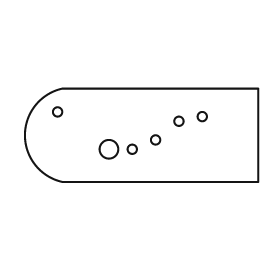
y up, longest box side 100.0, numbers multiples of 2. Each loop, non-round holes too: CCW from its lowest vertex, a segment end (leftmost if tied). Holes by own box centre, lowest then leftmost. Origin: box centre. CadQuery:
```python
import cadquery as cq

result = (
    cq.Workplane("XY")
    .moveTo(-34.0, -20.0)
    .lineTo(50.0, -20.0)
    .lineTo(50.0, 20.0)
    .lineTo(-34.0, 20.0)
    .threePointArc((-50.0, 0.0), (-34.0, -20.0))
    .close()
    .moveTo(-14.0, -6.0)
    .circle(4.0)
    .moveTo(-4.0, -6.0)
    .circle(2.0)
    .moveTo(6.0, -2.0)
    .circle(2.0)
    .moveTo(16.0, 6.0)
    .circle(2.0)
    .moveTo(26.0, 8.0)
    .circle(2.0)
    .moveTo(-36.0, 10.0)
    .circle(2.0)
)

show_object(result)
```